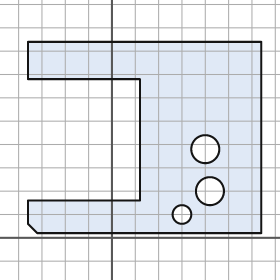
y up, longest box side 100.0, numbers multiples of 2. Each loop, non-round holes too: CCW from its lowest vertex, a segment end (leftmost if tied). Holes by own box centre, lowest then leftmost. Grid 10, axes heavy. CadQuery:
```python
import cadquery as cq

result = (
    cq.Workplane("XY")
    .moveTo(-32.0, 2.0)
    .lineTo(64.0, 2.0)
    .lineTo(64.0, 84.0)
    .lineTo(-36.0, 84.0)
    .lineTo(-36.0, 68.0)
    .lineTo(12.0, 68.0)
    .lineTo(12.0, 16.0)
    .lineTo(-36.0, 16.0)
    .lineTo(-36.0, 6.0)
    .close()
    .moveTo(30.0, 10.0)
    .circle(4.0)
    .moveTo(42.0, 20.0)
    .circle(6.0)
    .moveTo(40.0, 38.0)
    .circle(6.0)
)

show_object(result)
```